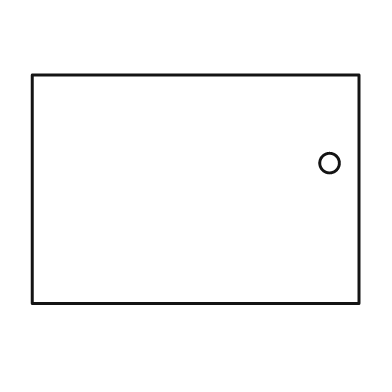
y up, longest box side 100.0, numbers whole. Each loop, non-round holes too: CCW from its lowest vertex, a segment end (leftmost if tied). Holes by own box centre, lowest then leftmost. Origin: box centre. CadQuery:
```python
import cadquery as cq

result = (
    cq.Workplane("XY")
    .moveTo(-50.0, -35.0)
    .lineTo(50.0, -35.0)
    .lineTo(50.0, 35.0)
    .lineTo(-50.0, 35.0)
    .close()
    .moveTo(41.0, 8.0)
    .circle(3.0)
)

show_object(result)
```